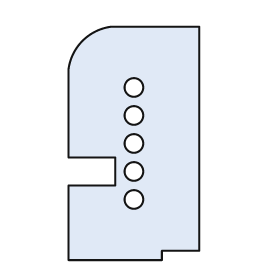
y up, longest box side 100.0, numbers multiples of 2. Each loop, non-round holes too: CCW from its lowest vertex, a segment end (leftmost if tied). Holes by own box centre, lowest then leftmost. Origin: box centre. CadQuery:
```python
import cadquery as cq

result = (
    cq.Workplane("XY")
    .moveTo(-28.0, -50.0)
    .lineTo(12.0, -50.0)
    .lineTo(12.0, -46.0)
    .lineTo(28.0, -46.0)
    .lineTo(28.0, 50.0)
    .lineTo(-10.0, 50.0)
    .threePointArc((-22.0, 44.0), (-28.0, 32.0))
    .lineTo(-28.0, -6.0)
    .lineTo(-8.0, -6.0)
    .lineTo(-8.0, -18.0)
    .lineTo(-28.0, -18.0)
    .close()
    .moveTo(0.0, -24.0)
    .circle(4.0)
    .moveTo(0.0, -12.0)
    .circle(4.0)
    .moveTo(0.0, 0.0)
    .circle(4.0)
    .moveTo(0.0, 12.0)
    .circle(4.0)
    .moveTo(0.0, 24.0)
    .circle(4.0)
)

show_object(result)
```